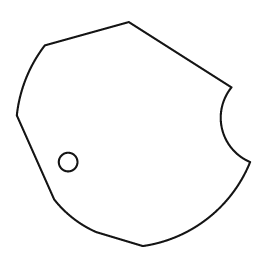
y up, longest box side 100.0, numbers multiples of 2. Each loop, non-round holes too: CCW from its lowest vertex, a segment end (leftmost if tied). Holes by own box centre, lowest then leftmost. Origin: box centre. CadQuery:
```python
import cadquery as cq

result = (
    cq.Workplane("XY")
    .moveTo(4.0, -48.0)
    .threePointArc((32.0, -36.0), (50.0, -12.0))
    .threePointArc((38.0, 2.0), (42.0, 20.0))
    .lineTo(-2.0, 48.0)
    .lineTo(-38.0, 38.0)
    .threePointArc((-46.0, 24.0), (-50.0, 8.0))
    .lineTo(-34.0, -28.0)
    .threePointArc((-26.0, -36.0), (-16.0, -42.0))
    .close()
    .moveTo(-28.0, -12.0)
    .circle(4.0)
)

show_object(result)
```